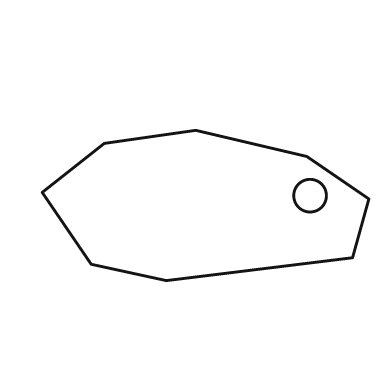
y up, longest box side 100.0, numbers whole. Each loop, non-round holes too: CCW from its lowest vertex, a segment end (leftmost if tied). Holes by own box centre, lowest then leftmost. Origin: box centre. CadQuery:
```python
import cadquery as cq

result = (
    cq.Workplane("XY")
    .moveTo(-12.0, -23.0)
    .lineTo(45.0, -16.0)
    .lineTo(50.0, 2.0)
    .lineTo(31.0, 15.0)
    .lineTo(-3.0, 23.0)
    .lineTo(-31.0, 19.0)
    .lineTo(-50.0, 4.0)
    .lineTo(-35.0, -18.0)
    .close()
    .moveTo(32.0, 3.0)
    .circle(5.0)
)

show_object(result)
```